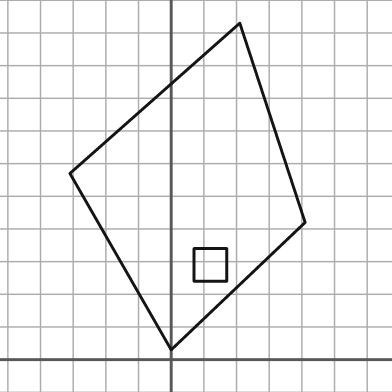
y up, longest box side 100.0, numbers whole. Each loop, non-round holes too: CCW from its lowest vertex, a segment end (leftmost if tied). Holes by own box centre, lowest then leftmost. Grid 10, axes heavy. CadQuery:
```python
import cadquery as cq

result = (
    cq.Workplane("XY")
    .moveTo(0.0, 3.0)
    .lineTo(41.0, 42.0)
    .lineTo(21.0, 103.0)
    .lineTo(-31.0, 57.0)
    .close()
    .moveTo(7.0, 24.0)
    .lineTo(17.0, 24.0)
    .lineTo(17.0, 34.0)
    .lineTo(7.0, 34.0)
    .close()
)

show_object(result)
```